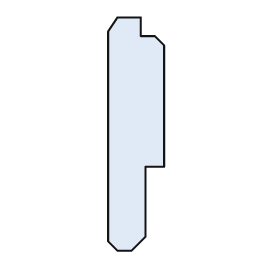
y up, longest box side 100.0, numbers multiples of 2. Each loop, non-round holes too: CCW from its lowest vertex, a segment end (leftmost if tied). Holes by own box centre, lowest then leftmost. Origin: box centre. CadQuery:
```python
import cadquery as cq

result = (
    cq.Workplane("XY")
    .moveTo(-8.0, -50.0)
    .lineTo(-2.0, -50.0)
    .lineTo(4.0, -44.0)
    .lineTo(4.0, -14.0)
    .lineTo(12.0, -14.0)
    .lineTo(12.0, 38.0)
    .lineTo(8.0, 42.0)
    .lineTo(2.0, 42.0)
    .lineTo(2.0, 50.0)
    .lineTo(-8.0, 50.0)
    .lineTo(-12.0, 44.0)
    .lineTo(-12.0, -46.0)
    .close()
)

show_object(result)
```